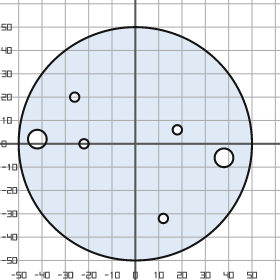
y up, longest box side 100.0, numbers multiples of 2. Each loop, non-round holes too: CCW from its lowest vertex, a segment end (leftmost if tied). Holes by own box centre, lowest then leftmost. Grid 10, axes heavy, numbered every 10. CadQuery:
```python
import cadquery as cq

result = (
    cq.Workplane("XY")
    .moveTo(0.0, 0.0)
    .circle(50.0)
    .moveTo(12.0, -32.0)
    .circle(2.0)
    .moveTo(38.0, -6.0)
    .circle(4.0)
    .moveTo(-22.0, 0.0)
    .circle(2.0)
    .moveTo(-42.0, 2.0)
    .circle(4.0)
    .moveTo(18.0, 6.0)
    .circle(2.0)
    .moveTo(-26.0, 20.0)
    .circle(2.0)
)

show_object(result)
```